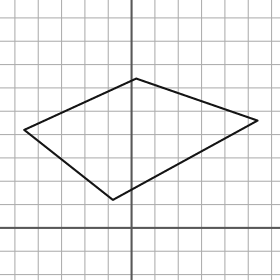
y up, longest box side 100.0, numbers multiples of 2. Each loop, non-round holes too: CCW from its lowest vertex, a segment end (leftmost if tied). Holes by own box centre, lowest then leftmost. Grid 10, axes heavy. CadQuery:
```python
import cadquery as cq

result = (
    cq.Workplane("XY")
    .moveTo(-8.0, 12.0)
    .lineTo(54.0, 46.0)
    .lineTo(2.0, 64.0)
    .lineTo(-46.0, 42.0)
    .close()
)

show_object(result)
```